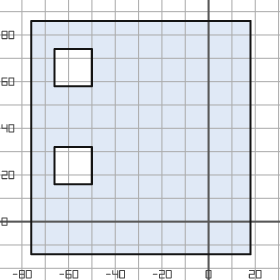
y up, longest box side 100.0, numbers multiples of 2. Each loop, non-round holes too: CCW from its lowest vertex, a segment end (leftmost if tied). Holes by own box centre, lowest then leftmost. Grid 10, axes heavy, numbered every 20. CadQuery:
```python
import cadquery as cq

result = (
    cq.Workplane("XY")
    .moveTo(-76.0, -14.0)
    .lineTo(18.0, -14.0)
    .lineTo(18.0, 86.0)
    .lineTo(-76.0, 86.0)
    .close()
    .moveTo(-66.0, 16.0)
    .lineTo(-50.0, 16.0)
    .lineTo(-50.0, 32.0)
    .lineTo(-66.0, 32.0)
    .close()
    .moveTo(-66.0, 58.0)
    .lineTo(-50.0, 58.0)
    .lineTo(-50.0, 74.0)
    .lineTo(-66.0, 74.0)
    .close()
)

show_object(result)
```